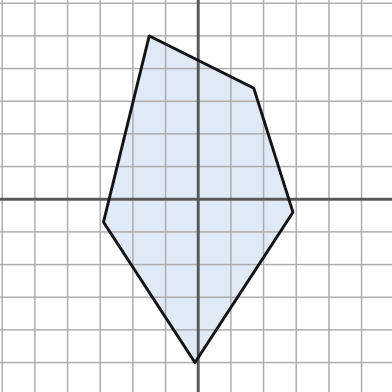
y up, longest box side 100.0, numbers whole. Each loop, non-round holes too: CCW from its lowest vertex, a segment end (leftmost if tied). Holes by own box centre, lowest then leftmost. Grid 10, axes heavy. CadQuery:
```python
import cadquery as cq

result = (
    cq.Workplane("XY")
    .moveTo(-1.0, -50.0)
    .lineTo(29.0, -4.0)
    .lineTo(17.0, 34.0)
    .lineTo(-15.0, 50.0)
    .lineTo(-29.0, -7.0)
    .close()
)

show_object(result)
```